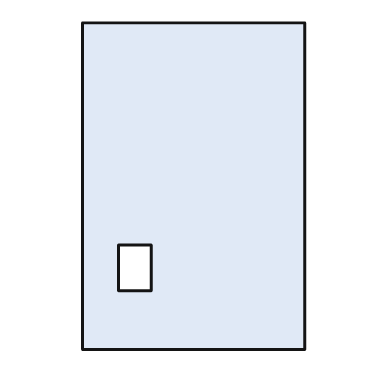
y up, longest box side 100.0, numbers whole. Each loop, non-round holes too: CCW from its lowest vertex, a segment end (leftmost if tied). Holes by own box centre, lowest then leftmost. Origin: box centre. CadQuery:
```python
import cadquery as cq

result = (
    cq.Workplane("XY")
    .moveTo(-34.0, -50.0)
    .lineTo(34.0, -50.0)
    .lineTo(34.0, 50.0)
    .lineTo(-34.0, 50.0)
    .close()
    .moveTo(-23.0, -32.0)
    .lineTo(-13.0, -32.0)
    .lineTo(-13.0, -18.0)
    .lineTo(-23.0, -18.0)
    .close()
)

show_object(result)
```